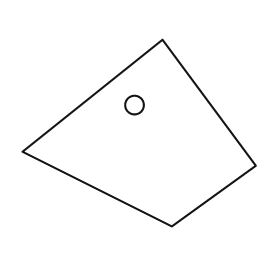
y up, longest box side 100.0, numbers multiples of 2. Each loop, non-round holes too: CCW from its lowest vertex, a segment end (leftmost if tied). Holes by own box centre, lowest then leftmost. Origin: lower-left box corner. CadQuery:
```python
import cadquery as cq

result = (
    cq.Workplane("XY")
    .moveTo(64.0, 0.0)
    .lineTo(100.0, 26.0)
    .lineTo(60.0, 80.0)
    .lineTo(0.0, 32.0)
    .close()
    .moveTo(48.0, 52.0)
    .circle(4.0)
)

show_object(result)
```